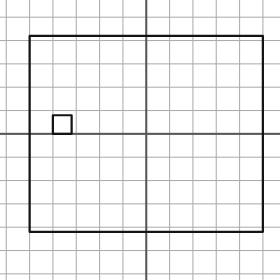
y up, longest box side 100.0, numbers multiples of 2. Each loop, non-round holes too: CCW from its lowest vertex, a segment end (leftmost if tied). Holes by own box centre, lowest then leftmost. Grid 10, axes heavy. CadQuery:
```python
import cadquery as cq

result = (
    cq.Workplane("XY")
    .moveTo(-50.0, -42.0)
    .lineTo(50.0, -42.0)
    .lineTo(50.0, 42.0)
    .lineTo(-50.0, 42.0)
    .close()
    .moveTo(-40.0, 0.0)
    .lineTo(-32.0, 0.0)
    .lineTo(-32.0, 8.0)
    .lineTo(-40.0, 8.0)
    .close()
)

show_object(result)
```